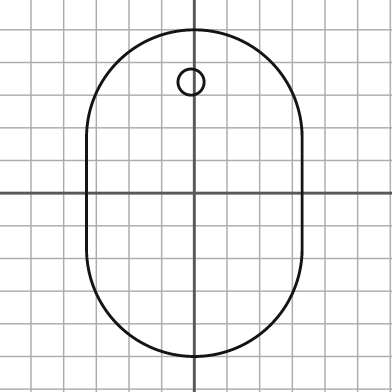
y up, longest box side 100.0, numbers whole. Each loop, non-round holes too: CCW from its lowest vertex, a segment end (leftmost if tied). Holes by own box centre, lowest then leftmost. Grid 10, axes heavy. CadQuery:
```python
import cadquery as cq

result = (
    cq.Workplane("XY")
    .moveTo(-33.0, -17.0)
    .threePointArc((0.0, -50.0), (33.0, -17.0))
    .lineTo(33.0, 17.0)
    .threePointArc((0.0, 50.0), (-33.0, 17.0))
    .close()
    .moveTo(-1.0, 34.0)
    .circle(4.0)
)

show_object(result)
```